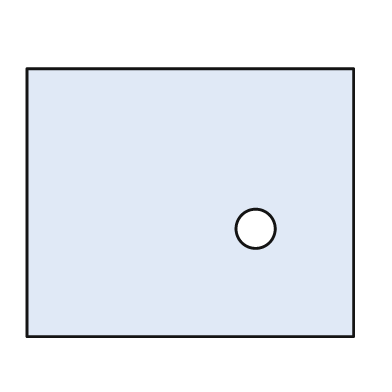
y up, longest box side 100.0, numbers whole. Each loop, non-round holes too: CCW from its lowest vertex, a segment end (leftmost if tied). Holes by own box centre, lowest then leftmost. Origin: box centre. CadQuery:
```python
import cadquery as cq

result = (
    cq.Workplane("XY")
    .moveTo(-50.0, -41.0)
    .lineTo(50.0, -41.0)
    .lineTo(50.0, 41.0)
    .lineTo(-50.0, 41.0)
    .close()
    .moveTo(20.0, -8.0)
    .circle(6.0)
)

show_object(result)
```